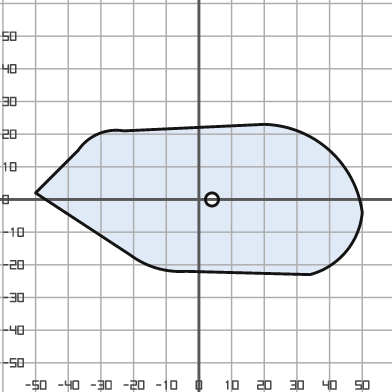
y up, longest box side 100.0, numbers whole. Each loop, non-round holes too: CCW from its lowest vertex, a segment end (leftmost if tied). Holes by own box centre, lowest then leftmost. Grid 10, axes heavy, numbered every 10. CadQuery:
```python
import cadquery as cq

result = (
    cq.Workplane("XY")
    .moveTo(34.0, -23.0)
    .threePointArc((45.0, -16.0), (50.0, -4.0))
    .threePointArc((40.0, 15.0), (20.0, 23.0))
    .lineTo(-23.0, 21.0)
    .threePointArc((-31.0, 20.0), (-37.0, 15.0))
    .lineTo(-50.0, 2.0)
    .lineTo(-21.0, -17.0)
    .threePointArc((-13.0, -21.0), (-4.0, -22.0))
    .close()
    .moveTo(4.0, 0.0)
    .circle(2.0)
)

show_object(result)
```